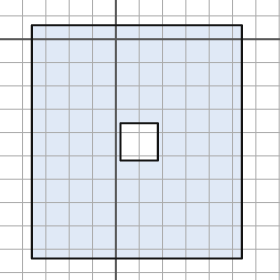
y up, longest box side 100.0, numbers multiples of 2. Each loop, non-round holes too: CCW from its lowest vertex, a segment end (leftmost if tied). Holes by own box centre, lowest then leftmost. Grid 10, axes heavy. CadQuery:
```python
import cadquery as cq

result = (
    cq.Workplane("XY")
    .moveTo(-36.0, -94.0)
    .lineTo(54.0, -94.0)
    .lineTo(54.0, 6.0)
    .lineTo(-36.0, 6.0)
    .close()
    .moveTo(2.0, -52.0)
    .lineTo(18.0, -52.0)
    .lineTo(18.0, -36.0)
    .lineTo(2.0, -36.0)
    .close()
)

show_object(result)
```